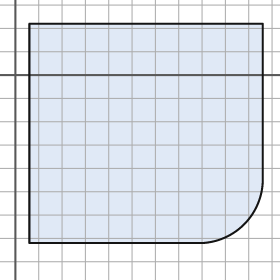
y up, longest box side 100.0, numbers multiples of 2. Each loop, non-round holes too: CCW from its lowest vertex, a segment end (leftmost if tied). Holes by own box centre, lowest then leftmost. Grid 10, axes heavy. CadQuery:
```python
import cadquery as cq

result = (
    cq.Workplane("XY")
    .moveTo(6.0, -72.0)
    .lineTo(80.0, -72.0)
    .threePointArc((98.0, -64.0), (106.0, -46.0))
    .lineTo(106.0, 22.0)
    .lineTo(6.0, 22.0)
    .close()
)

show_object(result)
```